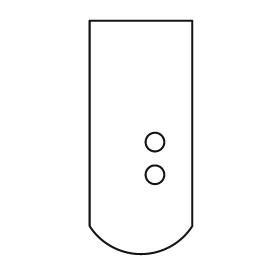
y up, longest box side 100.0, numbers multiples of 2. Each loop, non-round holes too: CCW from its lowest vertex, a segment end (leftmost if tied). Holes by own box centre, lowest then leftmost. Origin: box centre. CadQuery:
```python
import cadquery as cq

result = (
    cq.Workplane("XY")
    .moveTo(-22.0, -38.0)
    .threePointArc((0.0, -50.0), (22.0, -38.0))
    .lineTo(22.0, 50.0)
    .lineTo(-22.0, 50.0)
    .close()
    .moveTo(6.0, -16.0)
    .circle(4.0)
    .moveTo(6.0, -2.0)
    .circle(4.0)
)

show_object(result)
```